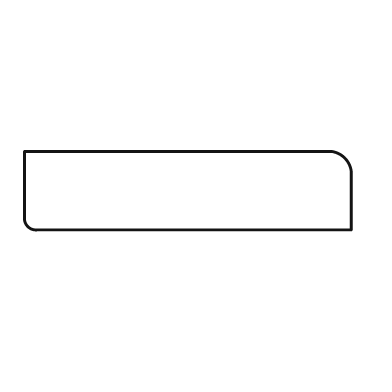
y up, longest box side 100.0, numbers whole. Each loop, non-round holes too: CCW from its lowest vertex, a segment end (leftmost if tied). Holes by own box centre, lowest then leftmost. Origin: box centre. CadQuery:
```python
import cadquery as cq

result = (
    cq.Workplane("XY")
    .moveTo(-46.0, -12.0)
    .lineTo(50.0, -12.0)
    .lineTo(50.0, 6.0)
    .threePointArc((48.0, 10.0), (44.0, 12.0))
    .lineTo(-50.0, 12.0)
    .lineTo(-50.0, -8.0)
    .threePointArc((-49.0, -11.0), (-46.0, -12.0))
    .close()
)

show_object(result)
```